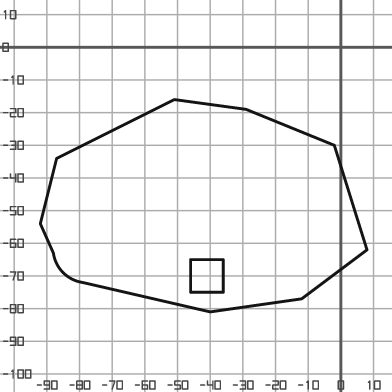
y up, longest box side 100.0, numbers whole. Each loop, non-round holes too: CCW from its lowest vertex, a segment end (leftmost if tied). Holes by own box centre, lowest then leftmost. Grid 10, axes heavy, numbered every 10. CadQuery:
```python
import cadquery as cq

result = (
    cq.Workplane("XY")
    .moveTo(-40.0, -81.0)
    .lineTo(-12.0, -77.0)
    .lineTo(8.0, -62.0)
    .lineTo(-2.0, -30.0)
    .lineTo(-29.0, -19.0)
    .lineTo(-51.0, -16.0)
    .lineTo(-87.0, -34.0)
    .lineTo(-92.0, -54.0)
    .lineTo(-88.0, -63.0)
    .threePointArc((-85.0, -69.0), (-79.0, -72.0))
    .close()
    .moveTo(-46.0, -75.0)
    .lineTo(-36.0, -75.0)
    .lineTo(-36.0, -65.0)
    .lineTo(-46.0, -65.0)
    .close()
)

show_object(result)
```